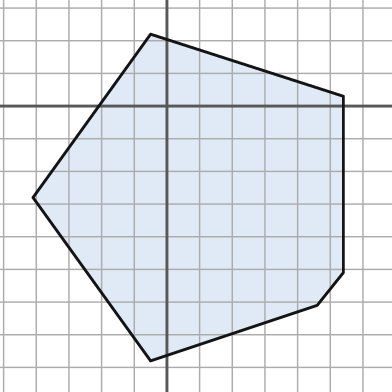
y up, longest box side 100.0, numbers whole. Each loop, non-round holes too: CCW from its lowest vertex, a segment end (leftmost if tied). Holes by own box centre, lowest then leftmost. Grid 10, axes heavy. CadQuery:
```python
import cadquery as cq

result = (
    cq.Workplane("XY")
    .moveTo(-5.0, -78.0)
    .lineTo(46.0, -61.0)
    .lineTo(54.0, -51.0)
    .lineTo(54.0, 3.0)
    .lineTo(-5.0, 22.0)
    .lineTo(-41.0, -28.0)
    .close()
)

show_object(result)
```